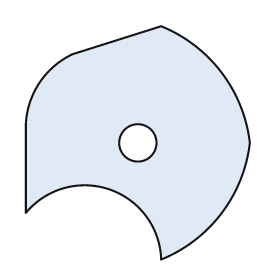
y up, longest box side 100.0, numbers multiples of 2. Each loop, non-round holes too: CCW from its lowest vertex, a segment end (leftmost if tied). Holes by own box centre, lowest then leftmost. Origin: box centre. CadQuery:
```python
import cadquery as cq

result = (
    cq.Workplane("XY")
    .moveTo(10.0, -50.0)
    .threePointArc((36.0, -30.0), (48.0, 0.0))
    .threePointArc((36.0, 30.0), (10.0, 50.0))
    .lineTo(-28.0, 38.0)
    .threePointArc((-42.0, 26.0), (-48.0, 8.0))
    .lineTo(-48.0, -30.0)
    .threePointArc((-12.0, -20.0), (10.0, -50.0))
    .close()
    .moveTo(0.0, 0.0)
    .circle(8.0)
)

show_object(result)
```